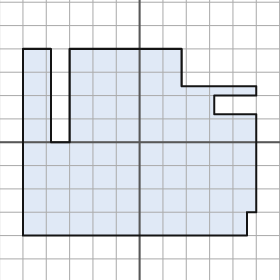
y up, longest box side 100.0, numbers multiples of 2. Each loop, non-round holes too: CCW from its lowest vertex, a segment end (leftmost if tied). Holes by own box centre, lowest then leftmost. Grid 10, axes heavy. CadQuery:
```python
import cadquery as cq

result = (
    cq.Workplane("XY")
    .moveTo(-50.0, -40.0)
    .lineTo(46.0, -40.0)
    .lineTo(46.0, -30.0)
    .lineTo(50.0, -30.0)
    .lineTo(50.0, 12.0)
    .lineTo(32.0, 12.0)
    .lineTo(32.0, 20.0)
    .lineTo(50.0, 20.0)
    .lineTo(50.0, 24.0)
    .lineTo(18.0, 24.0)
    .lineTo(18.0, 40.0)
    .lineTo(-30.0, 40.0)
    .lineTo(-30.0, 0.0)
    .lineTo(-38.0, 0.0)
    .lineTo(-38.0, 40.0)
    .lineTo(-50.0, 40.0)
    .close()
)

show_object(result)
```